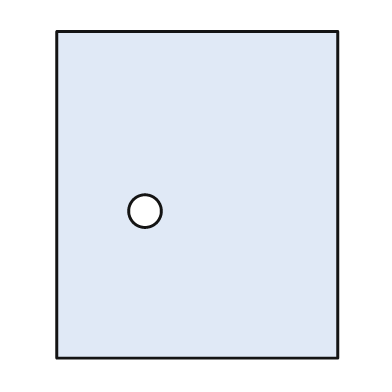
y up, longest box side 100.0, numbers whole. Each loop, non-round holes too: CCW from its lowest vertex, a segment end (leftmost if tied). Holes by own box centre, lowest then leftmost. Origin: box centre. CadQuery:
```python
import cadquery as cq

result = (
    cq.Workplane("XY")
    .moveTo(-43.0, -50.0)
    .lineTo(43.0, -50.0)
    .lineTo(43.0, 50.0)
    .lineTo(-43.0, 50.0)
    .close()
    .moveTo(-16.0, -5.0)
    .circle(5.0)
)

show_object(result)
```